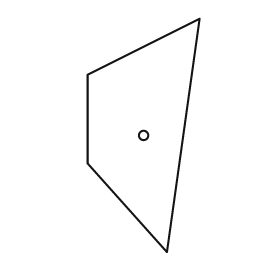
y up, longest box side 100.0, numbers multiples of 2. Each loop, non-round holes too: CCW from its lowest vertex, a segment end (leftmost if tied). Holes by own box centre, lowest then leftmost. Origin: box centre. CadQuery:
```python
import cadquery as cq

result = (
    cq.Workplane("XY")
    .moveTo(10.0, -50.0)
    .lineTo(24.0, 50.0)
    .lineTo(-24.0, 26.0)
    .lineTo(-24.0, -12.0)
    .close()
    .moveTo(0.0, 0.0)
    .circle(2.0)
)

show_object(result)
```